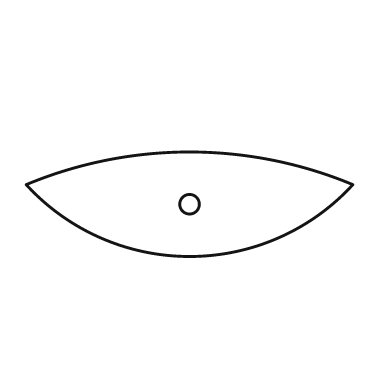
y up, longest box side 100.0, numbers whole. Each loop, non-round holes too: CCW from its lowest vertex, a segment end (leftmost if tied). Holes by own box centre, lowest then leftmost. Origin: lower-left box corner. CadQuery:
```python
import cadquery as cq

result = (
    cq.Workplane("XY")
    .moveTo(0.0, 22.0)
    .threePointArc((50.0, 0.0), (100.0, 22.0))
    .threePointArc((50.0, 32.0), (0.0, 22.0))
    .close()
    .moveTo(50.0, 16.0)
    .circle(3.0)
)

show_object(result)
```